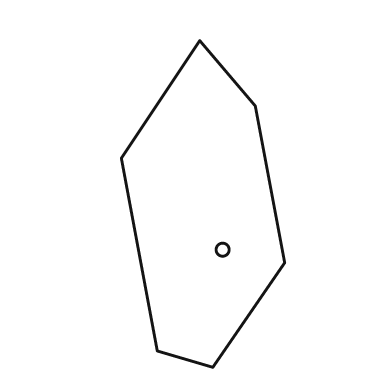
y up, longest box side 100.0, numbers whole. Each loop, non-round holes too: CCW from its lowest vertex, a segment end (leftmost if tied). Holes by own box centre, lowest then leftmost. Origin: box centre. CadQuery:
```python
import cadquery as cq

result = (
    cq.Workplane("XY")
    .moveTo(3.0, -50.0)
    .lineTo(25.0, -18.0)
    .lineTo(16.0, 30.0)
    .lineTo(-1.0, 50.0)
    .lineTo(-25.0, 14.0)
    .lineTo(-14.0, -45.0)
    .close()
    .moveTo(6.0, -14.0)
    .circle(2.0)
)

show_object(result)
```